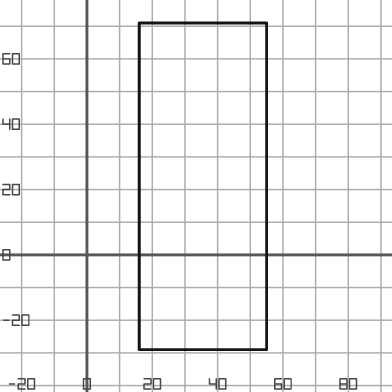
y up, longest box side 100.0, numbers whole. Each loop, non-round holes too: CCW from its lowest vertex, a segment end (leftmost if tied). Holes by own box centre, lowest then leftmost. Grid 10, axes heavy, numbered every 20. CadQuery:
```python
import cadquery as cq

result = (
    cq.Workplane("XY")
    .moveTo(16.0, -29.0)
    .lineTo(55.0, -29.0)
    .lineTo(55.0, 71.0)
    .lineTo(16.0, 71.0)
    .close()
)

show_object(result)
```